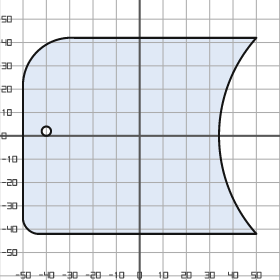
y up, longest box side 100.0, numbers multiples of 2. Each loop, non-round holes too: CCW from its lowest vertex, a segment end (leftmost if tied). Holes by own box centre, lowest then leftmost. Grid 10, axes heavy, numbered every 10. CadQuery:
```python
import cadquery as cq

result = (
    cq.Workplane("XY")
    .moveTo(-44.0, -42.0)
    .lineTo(50.0, -42.0)
    .threePointArc((34.0, 0.0), (50.0, 42.0))
    .lineTo(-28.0, 42.0)
    .threePointArc((-44.0, 36.0), (-50.0, 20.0))
    .lineTo(-50.0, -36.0)
    .threePointArc((-48.0, -40.0), (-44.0, -42.0))
    .close()
    .moveTo(-40.0, 2.0)
    .circle(2.0)
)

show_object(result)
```